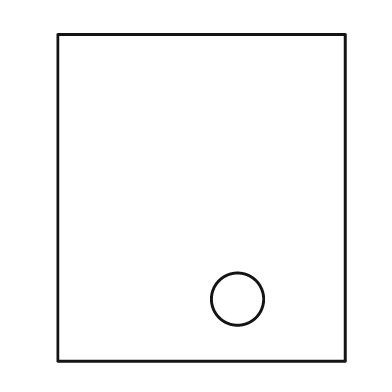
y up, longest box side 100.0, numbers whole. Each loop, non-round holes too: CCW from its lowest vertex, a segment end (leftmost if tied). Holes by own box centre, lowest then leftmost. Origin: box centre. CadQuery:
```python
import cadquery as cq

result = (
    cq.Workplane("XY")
    .moveTo(-44.0, -50.0)
    .lineTo(44.0, -50.0)
    .lineTo(44.0, 50.0)
    .lineTo(-44.0, 50.0)
    .close()
    .moveTo(11.0, -31.0)
    .circle(8.0)
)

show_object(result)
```